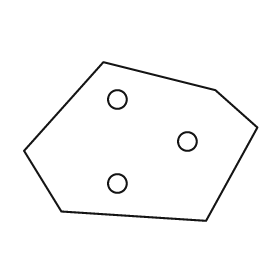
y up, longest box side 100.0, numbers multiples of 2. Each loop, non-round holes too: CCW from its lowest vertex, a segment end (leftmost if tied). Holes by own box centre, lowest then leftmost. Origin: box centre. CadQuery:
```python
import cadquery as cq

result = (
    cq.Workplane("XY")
    .moveTo(28.0, -34.0)
    .lineTo(50.0, 6.0)
    .lineTo(32.0, 22.0)
    .lineTo(-16.0, 34.0)
    .lineTo(-50.0, -4.0)
    .lineTo(-34.0, -30.0)
    .close()
    .moveTo(-10.0, -18.0)
    .circle(4.0)
    .moveTo(20.0, 0.0)
    .circle(4.0)
    .moveTo(-10.0, 18.0)
    .circle(4.0)
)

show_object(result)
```